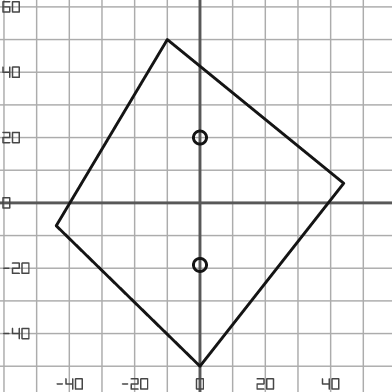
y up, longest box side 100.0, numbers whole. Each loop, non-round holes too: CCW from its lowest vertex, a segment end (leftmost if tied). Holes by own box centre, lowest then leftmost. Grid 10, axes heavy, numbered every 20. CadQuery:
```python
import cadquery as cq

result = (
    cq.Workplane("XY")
    .moveTo(0.0, -50.0)
    .lineTo(44.0, 6.0)
    .lineTo(-10.0, 50.0)
    .lineTo(-44.0, -7.0)
    .close()
    .moveTo(0.0, -19.0)
    .circle(2.0)
    .moveTo(0.0, 20.0)
    .circle(2.0)
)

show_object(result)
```